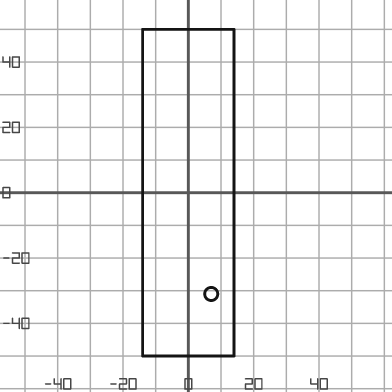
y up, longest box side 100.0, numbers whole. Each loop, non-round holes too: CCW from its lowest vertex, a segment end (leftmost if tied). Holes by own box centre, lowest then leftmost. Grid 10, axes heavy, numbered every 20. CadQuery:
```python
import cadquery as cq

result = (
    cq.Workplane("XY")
    .moveTo(-14.0, -50.0)
    .lineTo(14.0, -50.0)
    .lineTo(14.0, 50.0)
    .lineTo(-14.0, 50.0)
    .close()
    .moveTo(7.0, -31.0)
    .circle(2.0)
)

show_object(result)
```